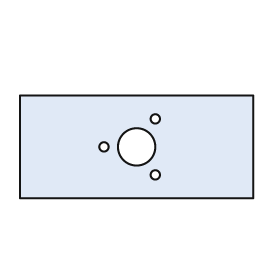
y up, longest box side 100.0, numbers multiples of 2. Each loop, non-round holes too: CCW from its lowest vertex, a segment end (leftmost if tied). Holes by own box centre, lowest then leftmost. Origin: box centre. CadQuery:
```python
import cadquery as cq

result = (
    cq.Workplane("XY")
    .moveTo(-50.0, -22.0)
    .lineTo(50.0, -22.0)
    .lineTo(50.0, 22.0)
    .lineTo(-50.0, 22.0)
    .close()
    .moveTo(8.0, -12.0)
    .circle(2.0)
    .moveTo(-14.0, 0.0)
    .circle(2.0)
    .moveTo(0.0, 0.0)
    .circle(8.0)
    .moveTo(8.0, 12.0)
    .circle(2.0)
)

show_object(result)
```